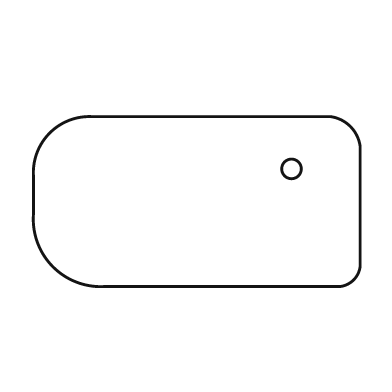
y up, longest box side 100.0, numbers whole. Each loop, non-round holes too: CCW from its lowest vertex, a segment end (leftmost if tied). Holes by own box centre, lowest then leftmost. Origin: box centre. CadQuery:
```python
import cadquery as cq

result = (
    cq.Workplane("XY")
    .moveTo(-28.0, -26.0)
    .lineTo(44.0, -26.0)
    .threePointArc((48.0, -24.0), (50.0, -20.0))
    .lineTo(50.0, 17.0)
    .threePointArc((47.0, 23.0), (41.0, 26.0))
    .lineTo(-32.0, 26.0)
    .threePointArc((-45.0, 21.0), (-50.0, 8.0))
    .lineTo(-50.0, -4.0)
    .threePointArc((-44.0, -20.0), (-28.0, -26.0))
    .close()
    .moveTo(29.0, 10.0)
    .circle(3.0)
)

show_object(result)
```